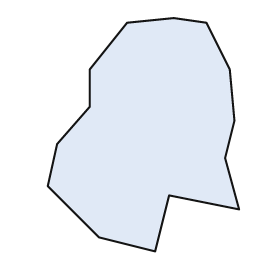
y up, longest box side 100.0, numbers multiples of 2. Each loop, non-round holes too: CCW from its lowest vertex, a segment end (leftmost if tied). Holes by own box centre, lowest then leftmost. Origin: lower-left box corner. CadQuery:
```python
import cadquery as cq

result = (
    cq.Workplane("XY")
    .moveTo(46.0, 0.0)
    .lineTo(52.0, 24.0)
    .lineTo(82.0, 18.0)
    .lineTo(76.0, 40.0)
    .lineTo(80.0, 56.0)
    .lineTo(78.0, 78.0)
    .lineTo(68.0, 98.0)
    .lineTo(54.0, 100.0)
    .lineTo(34.0, 98.0)
    .lineTo(18.0, 78.0)
    .lineTo(18.0, 62.0)
    .lineTo(4.0, 46.0)
    .lineTo(0.0, 28.0)
    .lineTo(22.0, 6.0)
    .close()
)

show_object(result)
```